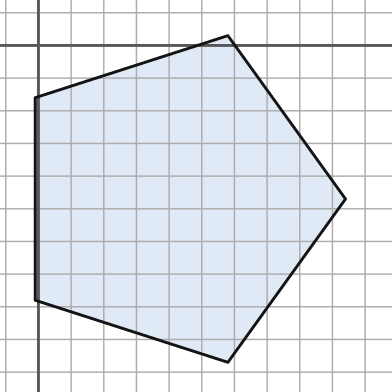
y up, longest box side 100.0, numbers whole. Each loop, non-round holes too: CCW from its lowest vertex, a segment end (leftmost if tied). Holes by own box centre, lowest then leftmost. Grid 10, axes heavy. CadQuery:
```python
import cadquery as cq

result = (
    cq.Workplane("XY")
    .moveTo(58.0, -97.0)
    .lineTo(94.0, -47.0)
    .lineTo(58.0, 3.0)
    .lineTo(-1.0, -16.0)
    .lineTo(-1.0, -78.0)
    .close()
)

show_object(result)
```